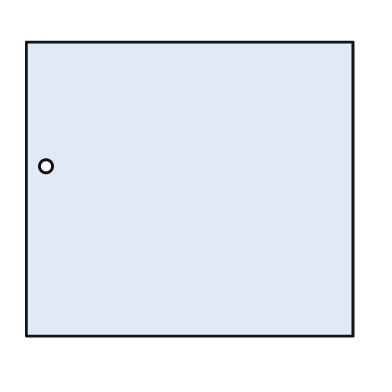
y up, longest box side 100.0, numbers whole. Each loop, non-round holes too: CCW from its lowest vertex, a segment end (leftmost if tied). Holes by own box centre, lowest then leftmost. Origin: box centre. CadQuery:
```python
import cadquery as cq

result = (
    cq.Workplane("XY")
    .moveTo(-50.0, -45.0)
    .lineTo(50.0, -45.0)
    .lineTo(50.0, 45.0)
    .lineTo(-50.0, 45.0)
    .close()
    .moveTo(-44.0, 7.0)
    .circle(2.0)
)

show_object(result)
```